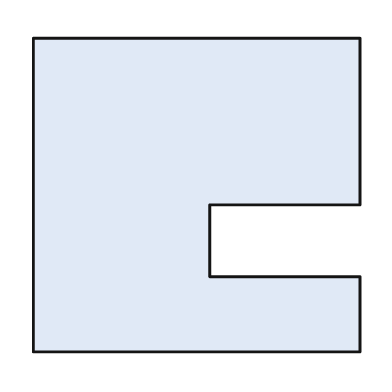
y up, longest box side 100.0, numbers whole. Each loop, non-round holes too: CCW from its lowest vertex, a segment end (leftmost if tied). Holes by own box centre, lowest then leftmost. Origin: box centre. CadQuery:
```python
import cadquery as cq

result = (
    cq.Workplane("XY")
    .moveTo(-50.0, -48.0)
    .lineTo(50.0, -48.0)
    .lineTo(50.0, -25.0)
    .lineTo(4.0, -25.0)
    .lineTo(4.0, -3.0)
    .lineTo(50.0, -3.0)
    .lineTo(50.0, 48.0)
    .lineTo(-50.0, 48.0)
    .close()
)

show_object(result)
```